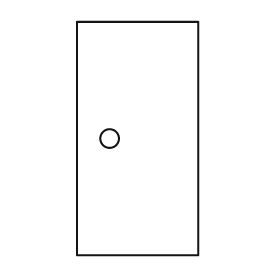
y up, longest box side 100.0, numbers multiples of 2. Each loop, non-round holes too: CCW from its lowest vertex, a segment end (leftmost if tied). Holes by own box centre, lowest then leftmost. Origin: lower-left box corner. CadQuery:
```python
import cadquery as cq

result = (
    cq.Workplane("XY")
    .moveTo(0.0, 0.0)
    .lineTo(52.0, 0.0)
    .lineTo(52.0, 100.0)
    .lineTo(0.0, 100.0)
    .close()
    .moveTo(14.0, 50.0)
    .circle(4.0)
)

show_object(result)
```